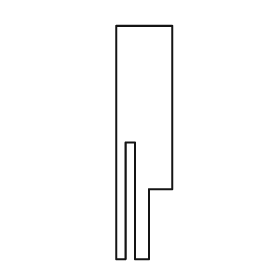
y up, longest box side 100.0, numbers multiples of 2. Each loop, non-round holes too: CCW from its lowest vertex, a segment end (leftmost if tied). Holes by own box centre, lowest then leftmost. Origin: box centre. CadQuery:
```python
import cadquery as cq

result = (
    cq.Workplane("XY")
    .moveTo(-12.0, -50.0)
    .lineTo(-8.0, -50.0)
    .lineTo(-8.0, 0.0)
    .lineTo(-4.0, 0.0)
    .lineTo(-4.0, -50.0)
    .lineTo(2.0, -50.0)
    .lineTo(2.0, -20.0)
    .lineTo(12.0, -20.0)
    .lineTo(12.0, 50.0)
    .lineTo(-12.0, 50.0)
    .close()
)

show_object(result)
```